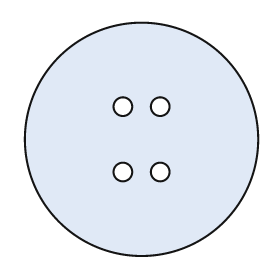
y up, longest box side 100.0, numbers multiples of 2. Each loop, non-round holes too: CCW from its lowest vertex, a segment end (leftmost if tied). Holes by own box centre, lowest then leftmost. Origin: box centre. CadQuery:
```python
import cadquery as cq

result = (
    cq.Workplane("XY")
    .moveTo(0.0, 0.0)
    .circle(50.0)
    .moveTo(-8.0, -14.0)
    .circle(4.0)
    .moveTo(8.0, -14.0)
    .circle(4.0)
    .moveTo(-8.0, 14.0)
    .circle(4.0)
    .moveTo(8.0, 14.0)
    .circle(4.0)
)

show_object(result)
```